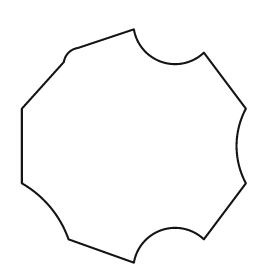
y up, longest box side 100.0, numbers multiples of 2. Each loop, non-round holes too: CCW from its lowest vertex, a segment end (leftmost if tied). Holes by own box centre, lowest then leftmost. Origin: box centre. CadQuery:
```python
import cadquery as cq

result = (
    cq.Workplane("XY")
    .moveTo(0.0, -50.0)
    .threePointArc((12.0, -36.0), (30.0, -40.0))
    .lineTo(48.0, -16.0)
    .threePointArc((44.0, 0.0), (48.0, 16.0))
    .lineTo(30.0, 40.0)
    .threePointArc((12.0, 36.0), (0.0, 50.0))
    .lineTo(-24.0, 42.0)
    .threePointArc((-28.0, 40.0), (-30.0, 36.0))
    .lineTo(-48.0, 16.0)
    .lineTo(-48.0, -16.0)
    .threePointArc((-36.0, -26.0), (-28.0, -40.0))
    .close()
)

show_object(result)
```